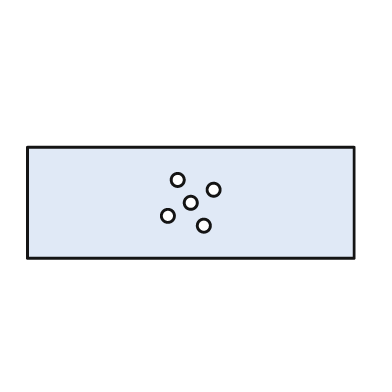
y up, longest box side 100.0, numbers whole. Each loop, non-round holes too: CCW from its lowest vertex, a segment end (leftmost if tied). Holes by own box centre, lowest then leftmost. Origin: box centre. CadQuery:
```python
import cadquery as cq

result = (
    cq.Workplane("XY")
    .moveTo(-50.0, -17.0)
    .lineTo(50.0, -17.0)
    .lineTo(50.0, 17.0)
    .lineTo(-50.0, 17.0)
    .close()
    .moveTo(4.0, -7.0)
    .circle(2.0)
    .moveTo(-7.0, -4.0)
    .circle(2.0)
    .moveTo(0.0, 0.0)
    .circle(2.0)
    .moveTo(7.0, 4.0)
    .circle(2.0)
    .moveTo(-4.0, 7.0)
    .circle(2.0)
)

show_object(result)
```